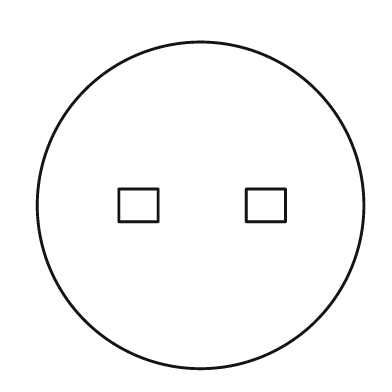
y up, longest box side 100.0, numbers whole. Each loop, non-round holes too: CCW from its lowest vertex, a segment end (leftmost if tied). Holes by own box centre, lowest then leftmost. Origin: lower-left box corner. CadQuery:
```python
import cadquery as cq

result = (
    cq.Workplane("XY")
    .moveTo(50.0, 50.0)
    .circle(50.0)
    .moveTo(25.0, 45.0)
    .lineTo(37.0, 45.0)
    .lineTo(37.0, 55.0)
    .lineTo(25.0, 55.0)
    .close()
    .moveTo(64.0, 45.0)
    .lineTo(76.0, 45.0)
    .lineTo(76.0, 55.0)
    .lineTo(64.0, 55.0)
    .close()
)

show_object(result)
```